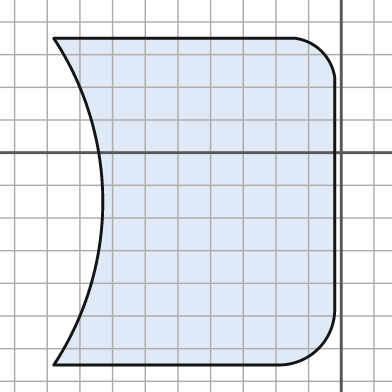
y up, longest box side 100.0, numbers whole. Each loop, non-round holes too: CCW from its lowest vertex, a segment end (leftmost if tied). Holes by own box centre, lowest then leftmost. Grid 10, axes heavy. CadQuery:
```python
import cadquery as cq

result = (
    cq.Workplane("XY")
    .moveTo(-88.0, -65.0)
    .lineTo(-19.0, -65.0)
    .threePointArc((-7.0, -60.0), (-2.0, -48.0))
    .lineTo(-2.0, 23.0)
    .threePointArc((-6.0, 31.0), (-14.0, 35.0))
    .lineTo(-88.0, 35.0)
    .threePointArc((-73.0, -15.0), (-88.0, -65.0))
    .close()
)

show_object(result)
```